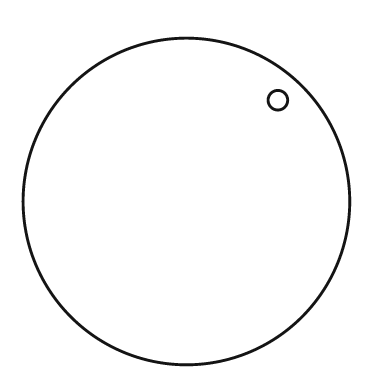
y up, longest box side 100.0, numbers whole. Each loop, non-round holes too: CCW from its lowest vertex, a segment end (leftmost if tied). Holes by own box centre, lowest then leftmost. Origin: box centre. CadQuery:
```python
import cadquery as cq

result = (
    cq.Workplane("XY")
    .moveTo(0.0, 0.0)
    .circle(50.0)
    .moveTo(28.0, 31.0)
    .circle(3.0)
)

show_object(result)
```